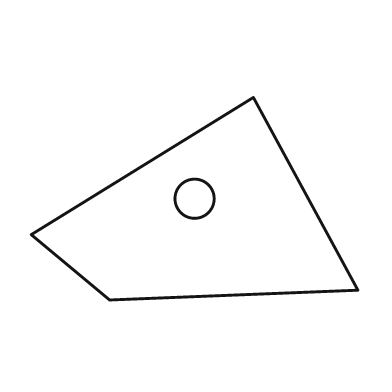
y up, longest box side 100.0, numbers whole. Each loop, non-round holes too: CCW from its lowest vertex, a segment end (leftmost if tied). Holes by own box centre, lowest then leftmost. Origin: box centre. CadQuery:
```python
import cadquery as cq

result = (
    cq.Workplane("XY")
    .moveTo(-26.0, -31.0)
    .lineTo(50.0, -28.0)
    .lineTo(18.0, 31.0)
    .lineTo(-50.0, -11.0)
    .close()
    .moveTo(0.0, 0.0)
    .circle(6.0)
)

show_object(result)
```